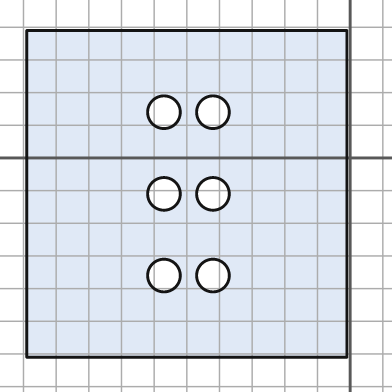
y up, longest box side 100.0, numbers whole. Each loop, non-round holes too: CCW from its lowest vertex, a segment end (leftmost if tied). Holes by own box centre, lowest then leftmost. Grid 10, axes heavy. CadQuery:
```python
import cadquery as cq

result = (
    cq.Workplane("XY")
    .moveTo(-99.0, -61.0)
    .lineTo(-1.0, -61.0)
    .lineTo(-1.0, 39.0)
    .lineTo(-99.0, 39.0)
    .close()
    .moveTo(-57.0, -36.0)
    .circle(5.0)
    .moveTo(-42.0, -36.0)
    .circle(5.0)
    .moveTo(-57.0, -11.0)
    .circle(5.0)
    .moveTo(-42.0, -11.0)
    .circle(5.0)
    .moveTo(-57.0, 14.0)
    .circle(5.0)
    .moveTo(-42.0, 14.0)
    .circle(5.0)
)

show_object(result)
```